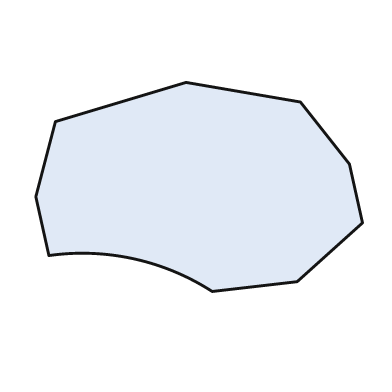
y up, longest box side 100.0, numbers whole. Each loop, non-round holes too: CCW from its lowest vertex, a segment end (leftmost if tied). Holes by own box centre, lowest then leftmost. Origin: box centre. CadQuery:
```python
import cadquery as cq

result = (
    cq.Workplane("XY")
    .moveTo(4.0, -32.0)
    .lineTo(30.0, -29.0)
    .lineTo(50.0, -11.0)
    .lineTo(46.0, 7.0)
    .lineTo(31.0, 26.0)
    .lineTo(-4.0, 32.0)
    .lineTo(-44.0, 20.0)
    .lineTo(-50.0, -3.0)
    .lineTo(-46.0, -21.0)
    .threePointArc((-20.0, -22.0), (4.0, -32.0))
    .close()
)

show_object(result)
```